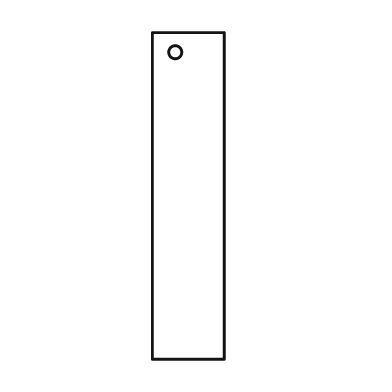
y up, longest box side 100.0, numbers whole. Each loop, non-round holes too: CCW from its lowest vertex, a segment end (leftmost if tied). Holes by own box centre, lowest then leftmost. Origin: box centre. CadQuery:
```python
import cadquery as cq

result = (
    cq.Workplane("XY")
    .moveTo(-11.0, -50.0)
    .lineTo(11.0, -50.0)
    .lineTo(11.0, 50.0)
    .lineTo(-11.0, 50.0)
    .close()
    .moveTo(-4.0, 44.0)
    .circle(2.0)
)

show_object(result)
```